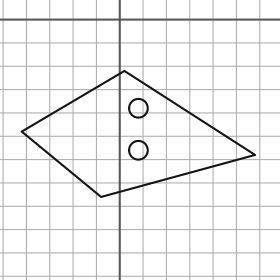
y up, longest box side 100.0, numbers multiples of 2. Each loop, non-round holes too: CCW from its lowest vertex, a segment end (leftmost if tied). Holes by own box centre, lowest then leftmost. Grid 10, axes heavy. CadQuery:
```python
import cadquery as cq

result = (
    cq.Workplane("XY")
    .moveTo(-8.0, -76.0)
    .lineTo(58.0, -58.0)
    .lineTo(2.0, -22.0)
    .lineTo(-42.0, -48.0)
    .close()
    .moveTo(8.0, -56.0)
    .circle(4.0)
    .moveTo(8.0, -38.0)
    .circle(4.0)
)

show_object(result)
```